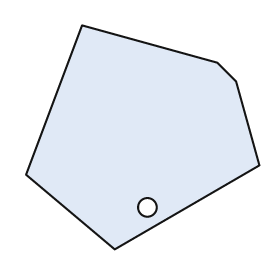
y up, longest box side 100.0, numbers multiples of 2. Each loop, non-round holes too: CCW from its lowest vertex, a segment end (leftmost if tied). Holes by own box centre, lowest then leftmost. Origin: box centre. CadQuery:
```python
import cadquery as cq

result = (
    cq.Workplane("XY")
    .moveTo(-12.0, -48.0)
    .lineTo(50.0, -12.0)
    .lineTo(40.0, 24.0)
    .lineTo(32.0, 32.0)
    .lineTo(-26.0, 48.0)
    .lineTo(-50.0, -16.0)
    .close()
    .moveTo(2.0, -30.0)
    .circle(4.0)
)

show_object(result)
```